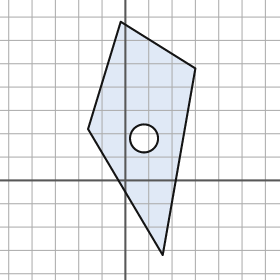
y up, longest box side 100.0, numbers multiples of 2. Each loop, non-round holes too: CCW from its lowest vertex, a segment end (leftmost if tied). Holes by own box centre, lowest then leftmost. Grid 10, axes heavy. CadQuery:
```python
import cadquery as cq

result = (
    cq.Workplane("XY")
    .moveTo(16.0, -32.0)
    .lineTo(30.0, 48.0)
    .lineTo(-2.0, 68.0)
    .lineTo(-16.0, 22.0)
    .close()
    .moveTo(8.0, 18.0)
    .circle(6.0)
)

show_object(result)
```